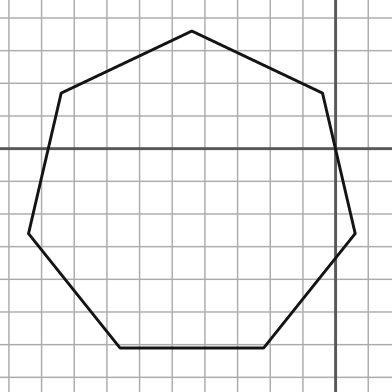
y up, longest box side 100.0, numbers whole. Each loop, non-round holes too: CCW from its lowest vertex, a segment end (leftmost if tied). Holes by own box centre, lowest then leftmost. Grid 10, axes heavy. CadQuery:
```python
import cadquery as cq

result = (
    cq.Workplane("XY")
    .moveTo(-66.0, -61.0)
    .lineTo(-22.0, -61.0)
    .lineTo(6.0, -26.0)
    .lineTo(-4.0, 17.0)
    .lineTo(-44.0, 36.0)
    .lineTo(-84.0, 17.0)
    .lineTo(-94.0, -26.0)
    .close()
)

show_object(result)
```